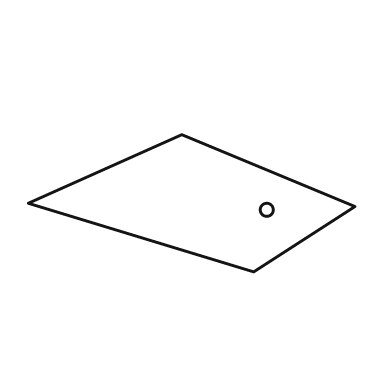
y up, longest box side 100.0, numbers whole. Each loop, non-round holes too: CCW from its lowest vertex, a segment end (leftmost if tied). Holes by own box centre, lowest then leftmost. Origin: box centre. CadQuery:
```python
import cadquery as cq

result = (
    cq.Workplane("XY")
    .moveTo(19.0, -21.0)
    .lineTo(50.0, -1.0)
    .lineTo(-3.0, 21.0)
    .lineTo(-50.0, 0.0)
    .close()
    .moveTo(23.0, -2.0)
    .circle(2.0)
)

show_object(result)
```